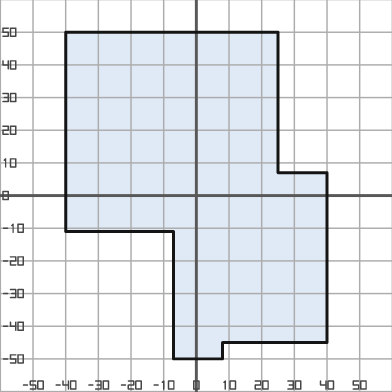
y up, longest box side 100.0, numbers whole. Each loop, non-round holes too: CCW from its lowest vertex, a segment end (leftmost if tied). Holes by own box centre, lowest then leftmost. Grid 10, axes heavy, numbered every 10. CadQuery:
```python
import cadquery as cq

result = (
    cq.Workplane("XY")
    .moveTo(-7.0, -50.0)
    .lineTo(8.0, -50.0)
    .lineTo(8.0, -45.0)
    .lineTo(40.0, -45.0)
    .lineTo(40.0, 7.0)
    .lineTo(25.0, 7.0)
    .lineTo(25.0, 50.0)
    .lineTo(-40.0, 50.0)
    .lineTo(-40.0, -11.0)
    .lineTo(-7.0, -11.0)
    .close()
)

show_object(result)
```